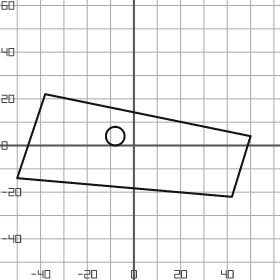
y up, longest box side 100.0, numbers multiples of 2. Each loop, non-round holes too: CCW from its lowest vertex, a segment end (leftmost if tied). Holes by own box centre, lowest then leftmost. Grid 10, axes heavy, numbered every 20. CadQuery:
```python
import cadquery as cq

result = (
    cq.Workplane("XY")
    .moveTo(42.0, -22.0)
    .lineTo(50.0, 4.0)
    .lineTo(-38.0, 22.0)
    .lineTo(-50.0, -14.0)
    .close()
    .moveTo(-8.0, 4.0)
    .circle(4.0)
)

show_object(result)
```